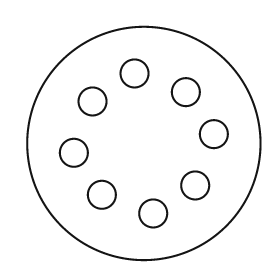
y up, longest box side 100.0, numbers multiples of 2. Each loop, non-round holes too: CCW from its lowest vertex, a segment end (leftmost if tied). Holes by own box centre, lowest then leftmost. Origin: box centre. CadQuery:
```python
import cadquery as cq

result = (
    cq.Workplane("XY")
    .moveTo(0.0, 0.0)
    .circle(50.0)
    .moveTo(4.0, -30.0)
    .circle(6.0)
    .moveTo(-18.0, -22.0)
    .circle(6.0)
    .moveTo(22.0, -18.0)
    .circle(6.0)
    .moveTo(-30.0, -4.0)
    .circle(6.0)
    .moveTo(30.0, 4.0)
    .circle(6.0)
    .moveTo(-22.0, 18.0)
    .circle(6.0)
    .moveTo(18.0, 22.0)
    .circle(6.0)
    .moveTo(-4.0, 30.0)
    .circle(6.0)
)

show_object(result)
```